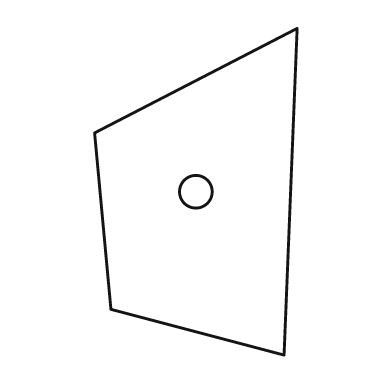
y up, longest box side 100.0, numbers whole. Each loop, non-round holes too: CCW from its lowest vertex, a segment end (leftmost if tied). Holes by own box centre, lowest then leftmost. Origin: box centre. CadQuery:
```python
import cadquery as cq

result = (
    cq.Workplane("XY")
    .moveTo(27.0, -50.0)
    .lineTo(31.0, 50.0)
    .lineTo(-31.0, 18.0)
    .lineTo(-26.0, -36.0)
    .close()
    .moveTo(0.0, 0.0)
    .circle(5.0)
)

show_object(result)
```